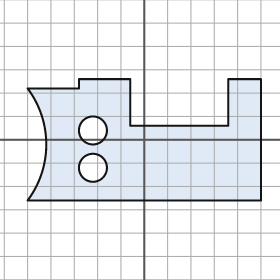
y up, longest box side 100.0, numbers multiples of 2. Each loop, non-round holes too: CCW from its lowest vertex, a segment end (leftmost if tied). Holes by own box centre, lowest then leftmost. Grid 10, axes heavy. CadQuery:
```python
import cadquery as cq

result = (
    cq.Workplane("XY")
    .moveTo(-50.0, -26.0)
    .lineTo(50.0, -26.0)
    .lineTo(50.0, 26.0)
    .lineTo(36.0, 26.0)
    .lineTo(36.0, 6.0)
    .lineTo(-6.0, 6.0)
    .lineTo(-6.0, 26.0)
    .lineTo(-28.0, 26.0)
    .lineTo(-28.0, 22.0)
    .lineTo(-50.0, 22.0)
    .threePointArc((-42.0, -2.0), (-50.0, -26.0))
    .close()
    .moveTo(-22.0, -12.0)
    .circle(6.0)
    .moveTo(-22.0, 4.0)
    .circle(6.0)
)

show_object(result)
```